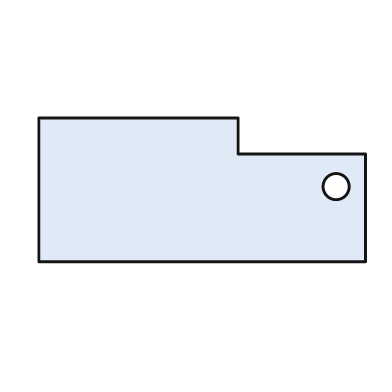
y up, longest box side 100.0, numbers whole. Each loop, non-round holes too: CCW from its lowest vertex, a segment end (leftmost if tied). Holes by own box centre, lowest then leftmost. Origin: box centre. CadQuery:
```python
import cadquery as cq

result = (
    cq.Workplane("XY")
    .moveTo(-50.0, -22.0)
    .lineTo(50.0, -22.0)
    .lineTo(50.0, 11.0)
    .lineTo(11.0, 11.0)
    .lineTo(11.0, 22.0)
    .lineTo(-50.0, 22.0)
    .close()
    .moveTo(41.0, 1.0)
    .circle(4.0)
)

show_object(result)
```